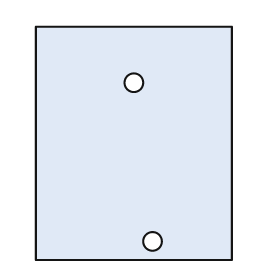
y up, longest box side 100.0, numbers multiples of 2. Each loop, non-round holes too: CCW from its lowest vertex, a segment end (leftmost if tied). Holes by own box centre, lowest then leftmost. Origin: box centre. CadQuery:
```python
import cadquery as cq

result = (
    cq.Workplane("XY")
    .moveTo(-42.0, -50.0)
    .lineTo(42.0, -50.0)
    .lineTo(42.0, 50.0)
    .lineTo(-42.0, 50.0)
    .close()
    .moveTo(8.0, -42.0)
    .circle(4.0)
    .moveTo(0.0, 26.0)
    .circle(4.0)
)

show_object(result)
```